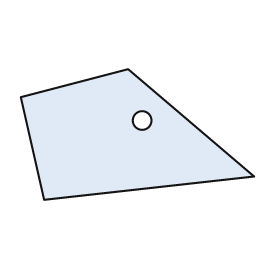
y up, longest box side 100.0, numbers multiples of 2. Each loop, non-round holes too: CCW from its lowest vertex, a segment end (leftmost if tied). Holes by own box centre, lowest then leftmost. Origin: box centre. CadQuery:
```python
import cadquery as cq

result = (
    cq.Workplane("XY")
    .moveTo(-40.0, -28.0)
    .lineTo(50.0, -18.0)
    .lineTo(-4.0, 28.0)
    .lineTo(-50.0, 16.0)
    .close()
    .moveTo(2.0, 6.0)
    .circle(4.0)
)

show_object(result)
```